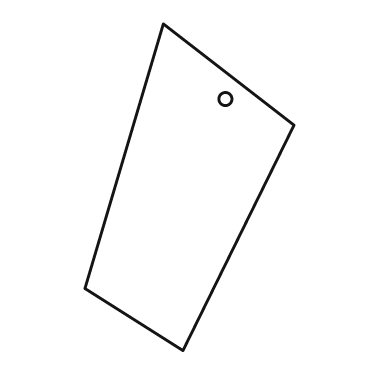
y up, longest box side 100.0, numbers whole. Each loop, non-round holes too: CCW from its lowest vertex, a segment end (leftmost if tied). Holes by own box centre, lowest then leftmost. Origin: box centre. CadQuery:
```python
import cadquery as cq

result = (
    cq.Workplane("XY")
    .moveTo(-2.0, -50.0)
    .lineTo(32.0, 19.0)
    .lineTo(-8.0, 50.0)
    .lineTo(-32.0, -31.0)
    .close()
    .moveTo(11.0, 27.0)
    .circle(2.0)
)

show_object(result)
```